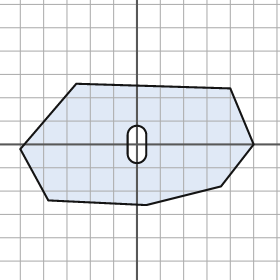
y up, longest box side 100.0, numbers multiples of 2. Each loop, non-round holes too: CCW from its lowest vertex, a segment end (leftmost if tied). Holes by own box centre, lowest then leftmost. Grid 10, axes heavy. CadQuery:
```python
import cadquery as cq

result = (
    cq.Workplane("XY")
    .moveTo(4.0, -26.0)
    .lineTo(36.0, -18.0)
    .lineTo(50.0, 0.0)
    .lineTo(40.0, 24.0)
    .lineTo(-26.0, 26.0)
    .lineTo(-50.0, -2.0)
    .lineTo(-38.0, -24.0)
    .close()
    .moveTo(-4.0, -4.0)
    .threePointArc((0.0, -8.0), (4.0, -4.0))
    .lineTo(4.0, 4.0)
    .threePointArc((0.0, 8.0), (-4.0, 4.0))
    .close()
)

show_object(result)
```